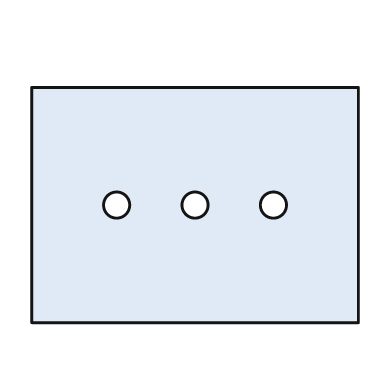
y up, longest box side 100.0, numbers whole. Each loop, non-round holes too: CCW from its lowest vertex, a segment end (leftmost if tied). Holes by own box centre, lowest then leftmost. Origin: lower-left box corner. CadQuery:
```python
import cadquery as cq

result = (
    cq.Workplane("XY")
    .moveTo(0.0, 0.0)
    .lineTo(100.0, 0.0)
    .lineTo(100.0, 72.0)
    .lineTo(0.0, 72.0)
    .close()
    .moveTo(26.0, 36.0)
    .circle(4.0)
    .moveTo(50.0, 36.0)
    .circle(4.0)
    .moveTo(74.0, 36.0)
    .circle(4.0)
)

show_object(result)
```